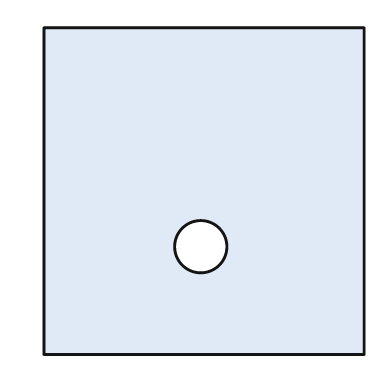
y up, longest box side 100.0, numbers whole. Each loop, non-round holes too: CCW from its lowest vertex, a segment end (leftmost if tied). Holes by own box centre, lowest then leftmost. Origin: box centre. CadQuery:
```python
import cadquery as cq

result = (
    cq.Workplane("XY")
    .moveTo(-49.0, -50.0)
    .lineTo(49.0, -50.0)
    .lineTo(49.0, 50.0)
    .lineTo(-49.0, 50.0)
    .close()
    .moveTo(-1.0, -17.0)
    .circle(8.0)
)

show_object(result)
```